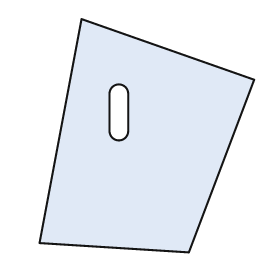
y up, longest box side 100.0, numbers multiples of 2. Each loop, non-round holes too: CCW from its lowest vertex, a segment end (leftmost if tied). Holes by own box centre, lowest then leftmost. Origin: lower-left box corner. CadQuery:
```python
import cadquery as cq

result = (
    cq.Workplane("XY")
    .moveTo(64.0, 0.0)
    .lineTo(92.0, 74.0)
    .lineTo(18.0, 100.0)
    .lineTo(0.0, 4.0)
    .close()
    .moveTo(30.0, 52.0)
    .threePointArc((34.0, 48.0), (38.0, 52.0))
    .lineTo(38.0, 68.0)
    .threePointArc((34.0, 72.0), (30.0, 68.0))
    .close()
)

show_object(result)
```